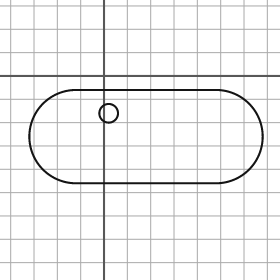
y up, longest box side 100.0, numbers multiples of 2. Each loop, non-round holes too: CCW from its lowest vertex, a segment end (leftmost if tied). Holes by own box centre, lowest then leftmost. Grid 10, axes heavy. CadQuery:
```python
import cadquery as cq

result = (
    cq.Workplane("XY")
    .moveTo(-12.0, -46.0)
    .lineTo(48.0, -46.0)
    .threePointArc((68.0, -26.0), (48.0, -6.0))
    .lineTo(-12.0, -6.0)
    .threePointArc((-32.0, -26.0), (-12.0, -46.0))
    .close()
    .moveTo(2.0, -16.0)
    .circle(4.0)
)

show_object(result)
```